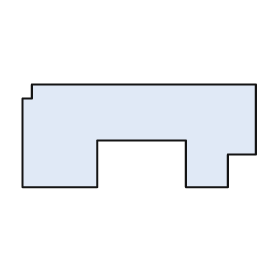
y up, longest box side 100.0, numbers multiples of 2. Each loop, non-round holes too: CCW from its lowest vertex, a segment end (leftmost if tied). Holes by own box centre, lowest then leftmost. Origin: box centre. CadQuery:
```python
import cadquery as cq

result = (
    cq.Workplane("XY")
    .moveTo(-50.0, -22.0)
    .lineTo(-18.0, -22.0)
    .lineTo(-18.0, -2.0)
    .lineTo(20.0, -2.0)
    .lineTo(20.0, -22.0)
    .lineTo(38.0, -22.0)
    .lineTo(38.0, -8.0)
    .lineTo(50.0, -8.0)
    .lineTo(50.0, 22.0)
    .lineTo(-46.0, 22.0)
    .lineTo(-46.0, 16.0)
    .lineTo(-50.0, 16.0)
    .close()
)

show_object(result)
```